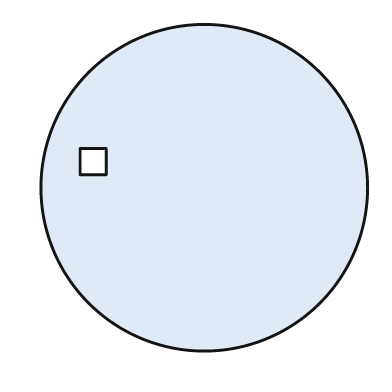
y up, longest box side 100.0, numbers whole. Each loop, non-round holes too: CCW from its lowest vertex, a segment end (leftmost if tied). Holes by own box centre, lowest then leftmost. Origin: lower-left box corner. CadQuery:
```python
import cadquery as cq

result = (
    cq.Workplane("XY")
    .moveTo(50.0, 50.0)
    .circle(50.0)
    .moveTo(12.0, 54.0)
    .lineTo(20.0, 54.0)
    .lineTo(20.0, 62.0)
    .lineTo(12.0, 62.0)
    .close()
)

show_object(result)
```